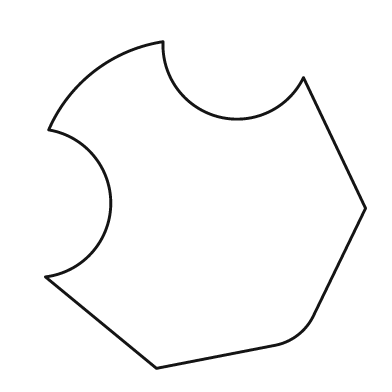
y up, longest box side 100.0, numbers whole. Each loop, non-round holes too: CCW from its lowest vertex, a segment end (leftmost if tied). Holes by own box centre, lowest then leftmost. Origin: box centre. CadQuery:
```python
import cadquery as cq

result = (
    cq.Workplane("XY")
    .moveTo(-15.0, -50.0)
    .lineTo(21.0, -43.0)
    .threePointArc((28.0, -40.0), (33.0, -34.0))
    .lineTo(49.0, -1.0)
    .lineTo(30.0, 39.0)
    .threePointArc((4.0, 27.0), (-13.0, 50.0))
    .threePointArc((-34.0, 41.0), (-48.0, 23.0))
    .threePointArc((-29.0, 0.0), (-49.0, -22.0))
    .close()
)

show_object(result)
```